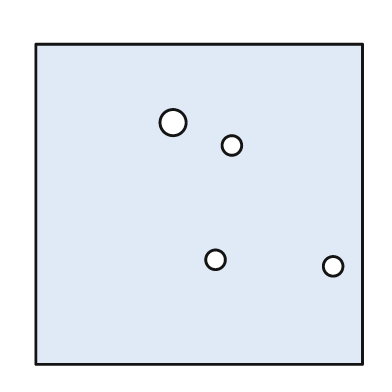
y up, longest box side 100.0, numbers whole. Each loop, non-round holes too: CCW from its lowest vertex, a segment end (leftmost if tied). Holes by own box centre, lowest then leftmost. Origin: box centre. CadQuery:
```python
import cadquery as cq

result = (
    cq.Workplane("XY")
    .moveTo(-50.0, -49.0)
    .lineTo(50.0, -49.0)
    .lineTo(50.0, 49.0)
    .lineTo(-50.0, 49.0)
    .close()
    .moveTo(41.0, -19.0)
    .circle(3.0)
    .moveTo(5.0, -17.0)
    .circle(3.0)
    .moveTo(10.0, 18.0)
    .circle(3.0)
    .moveTo(-8.0, 25.0)
    .circle(4.0)
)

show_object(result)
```